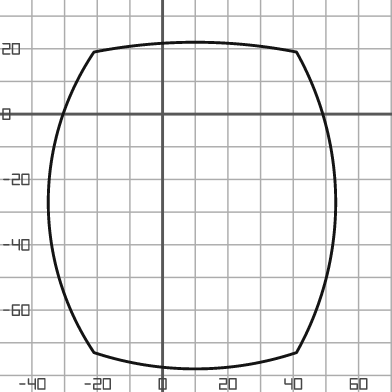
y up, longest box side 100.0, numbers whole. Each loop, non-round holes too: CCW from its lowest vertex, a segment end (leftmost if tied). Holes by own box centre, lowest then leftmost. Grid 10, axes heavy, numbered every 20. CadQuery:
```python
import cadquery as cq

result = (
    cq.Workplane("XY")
    .moveTo(-21.0, -73.0)
    .threePointArc((10.0, -78.0), (41.0, -73.0))
    .threePointArc((53.0, -27.0), (41.0, 19.0))
    .threePointArc((10.0, 22.0), (-21.0, 19.0))
    .threePointArc((-35.0, -27.0), (-21.0, -73.0))
    .close()
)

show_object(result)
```